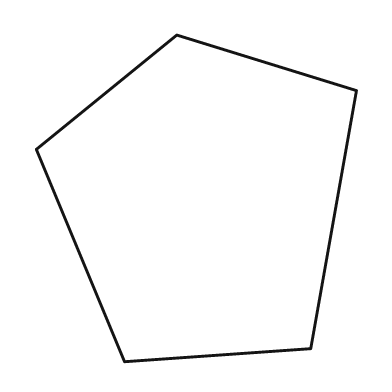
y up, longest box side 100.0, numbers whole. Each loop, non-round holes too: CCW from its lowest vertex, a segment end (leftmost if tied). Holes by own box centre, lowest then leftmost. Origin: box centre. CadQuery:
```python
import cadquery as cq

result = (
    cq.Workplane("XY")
    .moveTo(-22.0, -50.0)
    .lineTo(35.0, -46.0)
    .lineTo(49.0, 33.0)
    .lineTo(-6.0, 50.0)
    .lineTo(-49.0, 15.0)
    .close()
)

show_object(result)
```